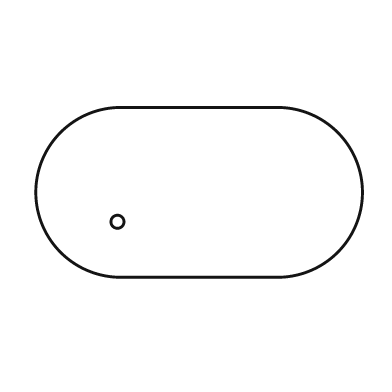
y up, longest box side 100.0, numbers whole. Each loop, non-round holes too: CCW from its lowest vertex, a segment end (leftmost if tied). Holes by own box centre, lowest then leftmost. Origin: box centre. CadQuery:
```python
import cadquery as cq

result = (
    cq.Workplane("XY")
    .moveTo(-24.0, -26.0)
    .lineTo(24.0, -26.0)
    .threePointArc((50.0, 0.0), (24.0, 26.0))
    .lineTo(-24.0, 26.0)
    .threePointArc((-50.0, 0.0), (-24.0, -26.0))
    .close()
    .moveTo(-25.0, -9.0)
    .circle(2.0)
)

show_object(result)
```